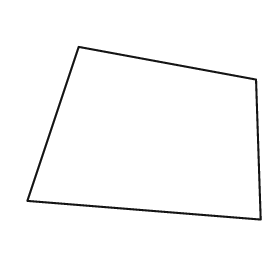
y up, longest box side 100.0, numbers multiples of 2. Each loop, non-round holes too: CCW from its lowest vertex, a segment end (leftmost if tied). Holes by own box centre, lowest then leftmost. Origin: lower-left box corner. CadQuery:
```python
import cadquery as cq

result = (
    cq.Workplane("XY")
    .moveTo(100.0, 0.0)
    .lineTo(98.0, 60.0)
    .lineTo(22.0, 74.0)
    .lineTo(0.0, 8.0)
    .close()
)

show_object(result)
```